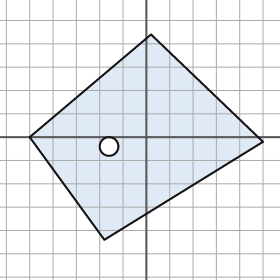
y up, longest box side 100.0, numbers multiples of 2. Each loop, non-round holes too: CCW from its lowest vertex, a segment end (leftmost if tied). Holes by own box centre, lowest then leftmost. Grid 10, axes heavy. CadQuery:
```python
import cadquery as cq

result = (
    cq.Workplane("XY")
    .moveTo(-18.0, -44.0)
    .lineTo(50.0, -2.0)
    .lineTo(2.0, 44.0)
    .lineTo(-50.0, 0.0)
    .close()
    .moveTo(-16.0, -4.0)
    .circle(4.0)
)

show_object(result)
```